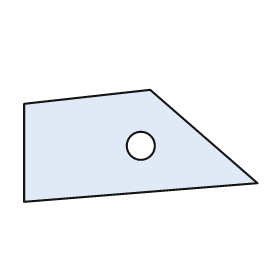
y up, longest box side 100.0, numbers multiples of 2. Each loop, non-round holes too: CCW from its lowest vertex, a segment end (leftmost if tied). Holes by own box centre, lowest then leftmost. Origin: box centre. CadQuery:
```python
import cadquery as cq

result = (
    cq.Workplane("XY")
    .moveTo(-50.0, -24.0)
    .lineTo(50.0, -16.0)
    .lineTo(4.0, 24.0)
    .lineTo(-50.0, 18.0)
    .close()
    .moveTo(0.0, 0.0)
    .circle(6.0)
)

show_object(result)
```